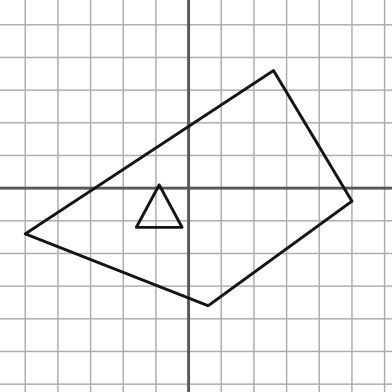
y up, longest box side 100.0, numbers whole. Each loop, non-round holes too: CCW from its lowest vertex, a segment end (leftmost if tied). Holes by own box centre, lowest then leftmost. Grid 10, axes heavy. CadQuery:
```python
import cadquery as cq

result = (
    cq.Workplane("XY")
    .moveTo(6.0, -36.0)
    .lineTo(50.0, -4.0)
    .lineTo(26.0, 36.0)
    .lineTo(-50.0, -14.0)
    .close()
    .moveTo(-16.0, -12.0)
    .lineTo(-2.0, -12.0)
    .lineTo(-9.0, 1.0)
    .close()
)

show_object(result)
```